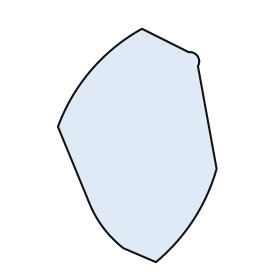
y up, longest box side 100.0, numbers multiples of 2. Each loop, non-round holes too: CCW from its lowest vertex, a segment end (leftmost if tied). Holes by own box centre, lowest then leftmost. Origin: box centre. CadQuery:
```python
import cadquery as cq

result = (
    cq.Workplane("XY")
    .moveTo(8.0, -50.0)
    .threePointArc((24.0, -32.0), (34.0, -10.0))
    .lineTo(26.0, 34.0)
    .threePointArc((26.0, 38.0), (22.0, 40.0))
    .lineTo(2.0, 50.0)
    .threePointArc((-20.0, 32.0), (-34.0, 8.0))
    .lineTo(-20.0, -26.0)
    .threePointArc((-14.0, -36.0), (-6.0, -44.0))
    .close()
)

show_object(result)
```